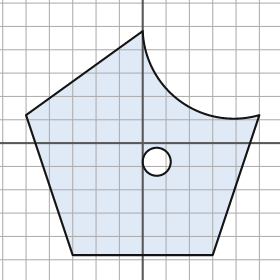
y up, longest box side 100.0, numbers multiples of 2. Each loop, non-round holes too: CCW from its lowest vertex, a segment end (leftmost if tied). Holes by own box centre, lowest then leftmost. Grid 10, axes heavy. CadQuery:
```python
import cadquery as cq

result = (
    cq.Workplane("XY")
    .moveTo(-30.0, -48.0)
    .lineTo(30.0, -48.0)
    .lineTo(50.0, 12.0)
    .threePointArc((16.0, 18.0), (0.0, 48.0))
    .lineTo(-50.0, 12.0)
    .close()
    .moveTo(6.0, -8.0)
    .circle(6.0)
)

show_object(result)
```